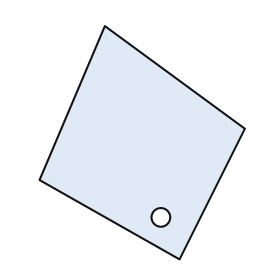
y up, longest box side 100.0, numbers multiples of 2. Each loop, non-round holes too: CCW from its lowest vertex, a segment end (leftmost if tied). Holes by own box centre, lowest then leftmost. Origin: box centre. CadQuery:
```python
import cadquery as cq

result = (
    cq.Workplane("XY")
    .moveTo(16.0, -50.0)
    .lineTo(44.0, 6.0)
    .lineTo(-16.0, 50.0)
    .lineTo(-44.0, -16.0)
    .close()
    .moveTo(8.0, -32.0)
    .circle(4.0)
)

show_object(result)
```